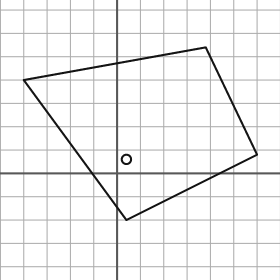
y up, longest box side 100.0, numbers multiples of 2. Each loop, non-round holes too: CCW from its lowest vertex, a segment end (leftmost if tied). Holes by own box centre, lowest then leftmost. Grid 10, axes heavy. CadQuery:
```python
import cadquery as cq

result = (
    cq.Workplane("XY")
    .moveTo(4.0, -20.0)
    .lineTo(60.0, 8.0)
    .lineTo(38.0, 54.0)
    .lineTo(-40.0, 40.0)
    .close()
    .moveTo(4.0, 6.0)
    .circle(2.0)
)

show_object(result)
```